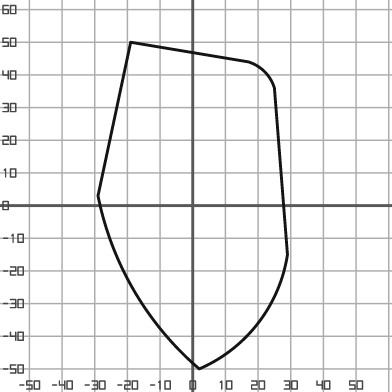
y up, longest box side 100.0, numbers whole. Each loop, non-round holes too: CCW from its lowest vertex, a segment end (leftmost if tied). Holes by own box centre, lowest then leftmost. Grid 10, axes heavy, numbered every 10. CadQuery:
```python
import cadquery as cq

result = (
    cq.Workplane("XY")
    .moveTo(2.0, -50.0)
    .threePointArc((20.0, -36.0), (29.0, -15.0))
    .lineTo(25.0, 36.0)
    .threePointArc((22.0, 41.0), (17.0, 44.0))
    .lineTo(-19.0, 50.0)
    .lineTo(-29.0, 3.0)
    .threePointArc((-18.0, -26.0), (2.0, -50.0))
    .close()
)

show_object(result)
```